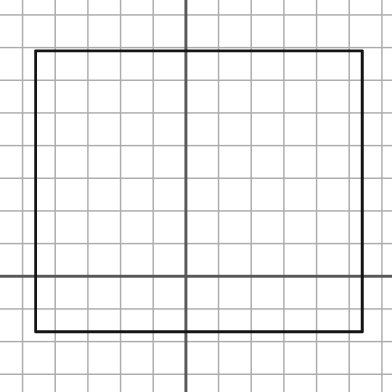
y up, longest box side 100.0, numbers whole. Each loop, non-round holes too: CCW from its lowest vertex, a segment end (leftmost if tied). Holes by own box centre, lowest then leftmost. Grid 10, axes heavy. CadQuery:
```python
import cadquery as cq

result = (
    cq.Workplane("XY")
    .moveTo(-46.0, -17.0)
    .lineTo(54.0, -17.0)
    .lineTo(54.0, 69.0)
    .lineTo(-46.0, 69.0)
    .close()
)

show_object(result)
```